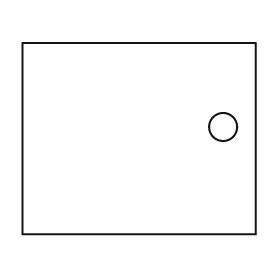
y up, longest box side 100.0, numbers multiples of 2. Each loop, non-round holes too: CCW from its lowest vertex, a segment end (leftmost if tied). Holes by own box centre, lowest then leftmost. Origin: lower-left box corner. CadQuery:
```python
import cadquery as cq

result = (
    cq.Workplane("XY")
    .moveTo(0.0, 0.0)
    .lineTo(100.0, 0.0)
    .lineTo(100.0, 82.0)
    .lineTo(0.0, 82.0)
    .close()
    .moveTo(86.0, 46.0)
    .circle(6.0)
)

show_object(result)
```